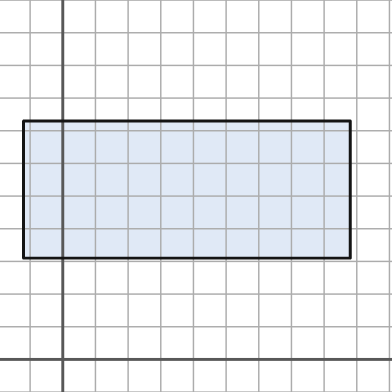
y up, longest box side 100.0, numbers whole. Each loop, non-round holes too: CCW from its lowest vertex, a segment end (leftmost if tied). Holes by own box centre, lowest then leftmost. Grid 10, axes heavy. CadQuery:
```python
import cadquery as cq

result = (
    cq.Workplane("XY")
    .moveTo(-12.0, 31.0)
    .lineTo(88.0, 31.0)
    .lineTo(88.0, 73.0)
    .lineTo(-12.0, 73.0)
    .close()
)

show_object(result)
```